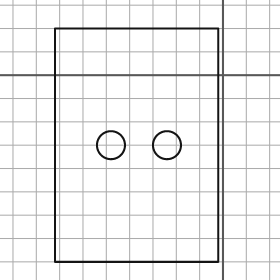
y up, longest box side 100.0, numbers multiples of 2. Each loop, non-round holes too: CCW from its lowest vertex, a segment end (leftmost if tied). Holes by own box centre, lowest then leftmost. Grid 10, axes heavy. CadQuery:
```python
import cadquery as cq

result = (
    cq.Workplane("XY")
    .moveTo(-72.0, -80.0)
    .lineTo(-2.0, -80.0)
    .lineTo(-2.0, 20.0)
    .lineTo(-72.0, 20.0)
    .close()
    .moveTo(-48.0, -30.0)
    .circle(6.0)
    .moveTo(-24.0, -30.0)
    .circle(6.0)
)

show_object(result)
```